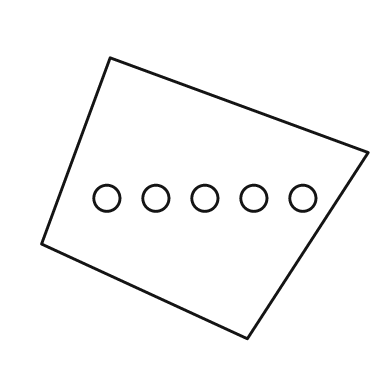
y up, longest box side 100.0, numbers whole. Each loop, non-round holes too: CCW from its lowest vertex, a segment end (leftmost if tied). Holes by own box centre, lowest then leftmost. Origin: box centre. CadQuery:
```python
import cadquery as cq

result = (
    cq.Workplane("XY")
    .moveTo(13.0, -43.0)
    .lineTo(50.0, 14.0)
    .lineTo(-29.0, 43.0)
    .lineTo(-50.0, -14.0)
    .close()
    .moveTo(-30.0, 0.0)
    .circle(4.0)
    .moveTo(-15.0, 0.0)
    .circle(4.0)
    .moveTo(0.0, 0.0)
    .circle(4.0)
    .moveTo(15.0, 0.0)
    .circle(4.0)
    .moveTo(30.0, 0.0)
    .circle(4.0)
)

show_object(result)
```